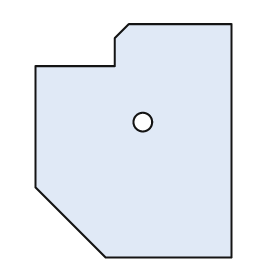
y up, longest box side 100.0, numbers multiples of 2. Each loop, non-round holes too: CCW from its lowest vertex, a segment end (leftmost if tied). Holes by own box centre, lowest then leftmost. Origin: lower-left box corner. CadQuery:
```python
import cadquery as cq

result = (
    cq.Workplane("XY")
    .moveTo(30.0, 0.0)
    .lineTo(84.0, 0.0)
    .lineTo(84.0, 100.0)
    .lineTo(40.0, 100.0)
    .lineTo(34.0, 94.0)
    .lineTo(34.0, 82.0)
    .lineTo(0.0, 82.0)
    .lineTo(0.0, 30.0)
    .close()
    .moveTo(46.0, 58.0)
    .circle(4.0)
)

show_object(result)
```